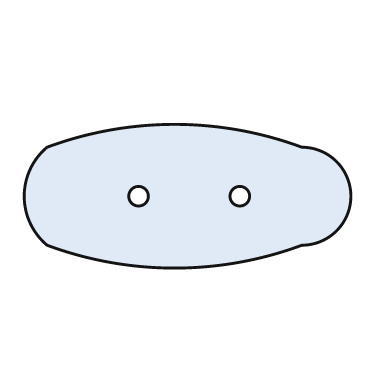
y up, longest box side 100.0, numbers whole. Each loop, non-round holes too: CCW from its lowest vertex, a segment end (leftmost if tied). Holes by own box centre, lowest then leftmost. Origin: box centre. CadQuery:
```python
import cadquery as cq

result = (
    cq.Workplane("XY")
    .moveTo(-43.0, -15.0)
    .threePointArc((-4.0, -22.0), (35.0, -15.0))
    .threePointArc((50.0, 0.0), (35.0, 15.0))
    .threePointArc((-4.0, 22.0), (-43.0, 15.0))
    .threePointArc((-50.0, 0.0), (-43.0, -15.0))
    .close()
    .moveTo(-15.0, 0.0)
    .circle(3.0)
    .moveTo(16.0, 0.0)
    .circle(3.0)
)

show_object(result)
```